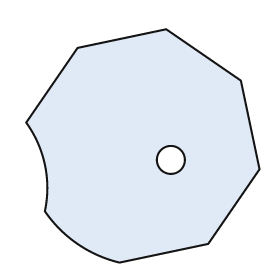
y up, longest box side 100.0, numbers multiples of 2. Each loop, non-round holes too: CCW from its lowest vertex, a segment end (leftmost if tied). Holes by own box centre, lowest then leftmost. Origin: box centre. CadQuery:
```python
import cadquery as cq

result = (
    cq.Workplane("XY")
    .moveTo(-10.0, -50.0)
    .lineTo(28.0, -42.0)
    .lineTo(50.0, -10.0)
    .lineTo(42.0, 28.0)
    .lineTo(10.0, 50.0)
    .lineTo(-28.0, 42.0)
    .lineTo(-50.0, 10.0)
    .threePointArc((-42.0, -8.0), (-42.0, -28.0))
    .threePointArc((-28.0, -42.0), (-10.0, -50.0))
    .close()
    .moveTo(12.0, -6.0)
    .circle(6.0)
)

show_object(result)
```